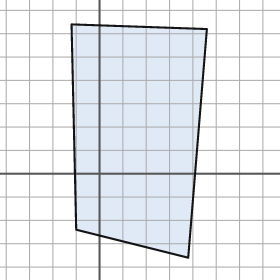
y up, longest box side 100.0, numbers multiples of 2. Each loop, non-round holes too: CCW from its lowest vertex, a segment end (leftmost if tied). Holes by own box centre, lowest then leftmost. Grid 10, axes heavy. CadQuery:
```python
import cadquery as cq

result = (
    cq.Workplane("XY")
    .moveTo(38.0, -36.0)
    .lineTo(46.0, 62.0)
    .lineTo(-12.0, 64.0)
    .lineTo(-10.0, -24.0)
    .close()
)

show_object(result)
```